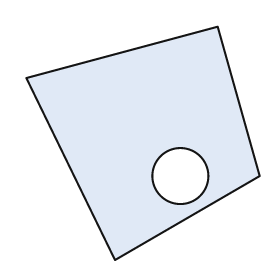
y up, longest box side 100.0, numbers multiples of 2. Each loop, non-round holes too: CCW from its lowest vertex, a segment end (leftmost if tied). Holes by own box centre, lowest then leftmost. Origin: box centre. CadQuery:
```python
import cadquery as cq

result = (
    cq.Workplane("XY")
    .moveTo(-12.0, -50.0)
    .lineTo(50.0, -14.0)
    .lineTo(32.0, 50.0)
    .lineTo(-50.0, 28.0)
    .close()
    .moveTo(16.0, -14.0)
    .circle(12.0)
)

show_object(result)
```